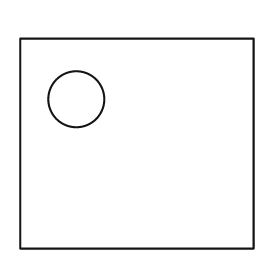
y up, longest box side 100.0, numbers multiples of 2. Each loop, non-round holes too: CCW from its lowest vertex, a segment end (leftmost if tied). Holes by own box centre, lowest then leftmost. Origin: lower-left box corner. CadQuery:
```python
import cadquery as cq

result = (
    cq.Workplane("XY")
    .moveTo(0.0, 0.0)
    .lineTo(100.0, 0.0)
    .lineTo(100.0, 90.0)
    .lineTo(0.0, 90.0)
    .close()
    .moveTo(24.0, 64.0)
    .circle(12.0)
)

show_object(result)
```